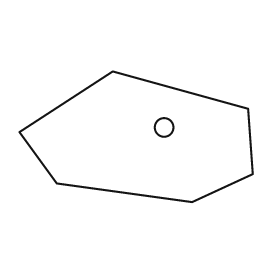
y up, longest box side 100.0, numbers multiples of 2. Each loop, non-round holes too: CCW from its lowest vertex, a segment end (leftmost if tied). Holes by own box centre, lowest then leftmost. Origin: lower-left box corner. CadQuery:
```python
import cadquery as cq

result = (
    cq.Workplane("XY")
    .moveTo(74.0, 0.0)
    .lineTo(100.0, 12.0)
    .lineTo(98.0, 40.0)
    .lineTo(40.0, 56.0)
    .lineTo(0.0, 30.0)
    .lineTo(16.0, 8.0)
    .close()
    .moveTo(62.0, 32.0)
    .circle(4.0)
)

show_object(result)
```